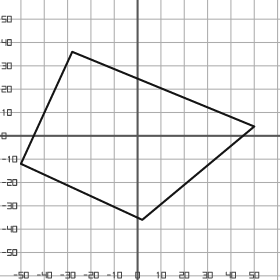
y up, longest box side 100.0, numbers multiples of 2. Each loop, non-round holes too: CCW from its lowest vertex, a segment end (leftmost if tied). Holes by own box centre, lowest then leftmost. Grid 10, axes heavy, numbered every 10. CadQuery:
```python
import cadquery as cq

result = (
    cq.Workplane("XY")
    .moveTo(2.0, -36.0)
    .lineTo(50.0, 4.0)
    .lineTo(-28.0, 36.0)
    .lineTo(-50.0, -12.0)
    .close()
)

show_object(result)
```